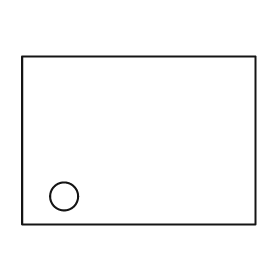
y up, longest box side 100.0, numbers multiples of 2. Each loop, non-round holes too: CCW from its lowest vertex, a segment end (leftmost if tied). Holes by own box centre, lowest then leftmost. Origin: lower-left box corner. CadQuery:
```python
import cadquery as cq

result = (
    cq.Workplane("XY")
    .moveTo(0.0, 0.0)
    .lineTo(100.0, 0.0)
    .lineTo(100.0, 72.0)
    .lineTo(0.0, 72.0)
    .close()
    .moveTo(18.0, 12.0)
    .circle(6.0)
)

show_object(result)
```